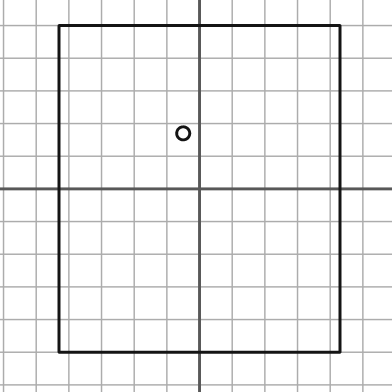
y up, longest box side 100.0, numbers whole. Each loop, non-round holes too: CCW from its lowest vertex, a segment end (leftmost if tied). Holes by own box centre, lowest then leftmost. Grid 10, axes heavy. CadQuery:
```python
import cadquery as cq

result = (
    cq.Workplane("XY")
    .moveTo(-43.0, -50.0)
    .lineTo(43.0, -50.0)
    .lineTo(43.0, 50.0)
    .lineTo(-43.0, 50.0)
    .close()
    .moveTo(-5.0, 17.0)
    .circle(2.0)
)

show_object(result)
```